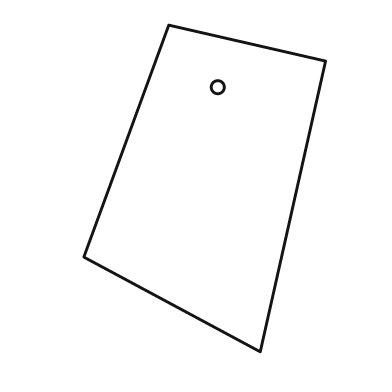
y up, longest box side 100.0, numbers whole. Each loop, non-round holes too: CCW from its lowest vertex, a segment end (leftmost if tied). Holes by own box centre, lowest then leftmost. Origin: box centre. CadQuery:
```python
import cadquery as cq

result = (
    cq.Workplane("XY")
    .moveTo(17.0, -50.0)
    .lineTo(37.0, 39.0)
    .lineTo(-11.0, 50.0)
    .lineTo(-37.0, -21.0)
    .close()
    .moveTo(4.0, 31.0)
    .circle(2.0)
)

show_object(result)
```